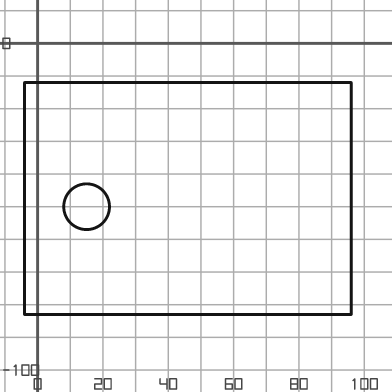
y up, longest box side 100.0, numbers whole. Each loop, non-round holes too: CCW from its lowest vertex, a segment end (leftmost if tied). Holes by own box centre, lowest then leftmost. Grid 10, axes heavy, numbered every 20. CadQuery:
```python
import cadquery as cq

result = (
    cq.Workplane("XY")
    .moveTo(-4.0, -83.0)
    .lineTo(96.0, -83.0)
    .lineTo(96.0, -12.0)
    .lineTo(-4.0, -12.0)
    .close()
    .moveTo(15.0, -50.0)
    .circle(7.0)
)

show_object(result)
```